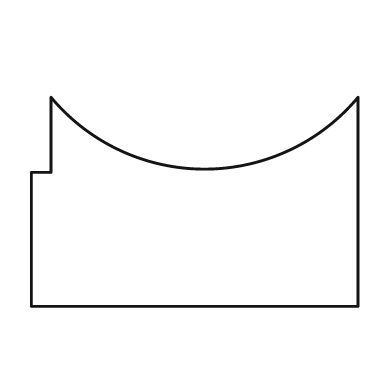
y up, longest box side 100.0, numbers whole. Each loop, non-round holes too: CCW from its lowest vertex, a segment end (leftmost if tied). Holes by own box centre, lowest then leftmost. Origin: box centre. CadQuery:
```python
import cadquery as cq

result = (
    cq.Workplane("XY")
    .moveTo(-50.0, -32.0)
    .lineTo(50.0, -32.0)
    .lineTo(50.0, 32.0)
    .threePointArc((3.0, 10.0), (-44.0, 32.0))
    .lineTo(-44.0, 9.0)
    .lineTo(-50.0, 9.0)
    .close()
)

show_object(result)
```